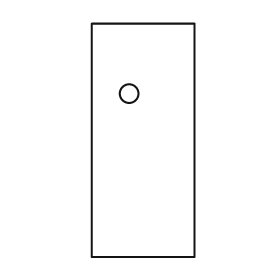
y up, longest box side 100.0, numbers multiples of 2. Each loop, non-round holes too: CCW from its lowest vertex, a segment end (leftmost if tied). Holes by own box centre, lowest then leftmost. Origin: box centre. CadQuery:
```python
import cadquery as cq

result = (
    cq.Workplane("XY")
    .moveTo(-22.0, -50.0)
    .lineTo(22.0, -50.0)
    .lineTo(22.0, 50.0)
    .lineTo(-22.0, 50.0)
    .close()
    .moveTo(-6.0, 20.0)
    .circle(4.0)
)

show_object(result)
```